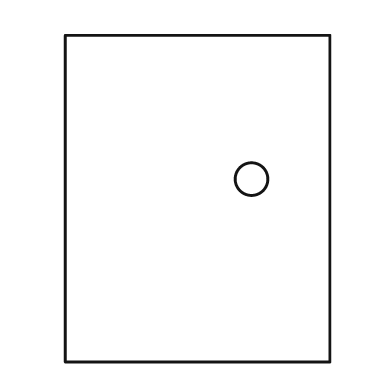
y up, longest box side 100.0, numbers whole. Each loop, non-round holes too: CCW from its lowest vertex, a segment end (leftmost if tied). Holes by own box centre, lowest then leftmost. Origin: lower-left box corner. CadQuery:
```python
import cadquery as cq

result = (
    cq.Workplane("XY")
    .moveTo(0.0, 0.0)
    .lineTo(81.0, 0.0)
    .lineTo(81.0, 100.0)
    .lineTo(0.0, 100.0)
    .close()
    .moveTo(57.0, 56.0)
    .circle(5.0)
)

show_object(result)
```